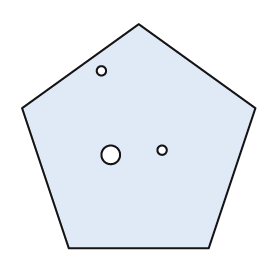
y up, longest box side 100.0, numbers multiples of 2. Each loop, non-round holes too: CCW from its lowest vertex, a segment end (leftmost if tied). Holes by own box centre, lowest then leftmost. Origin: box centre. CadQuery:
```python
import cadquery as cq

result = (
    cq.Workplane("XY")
    .moveTo(-30.0, -48.0)
    .lineTo(30.0, -48.0)
    .lineTo(50.0, 12.0)
    .lineTo(0.0, 48.0)
    .lineTo(-50.0, 12.0)
    .close()
    .moveTo(-12.0, -8.0)
    .circle(4.0)
    .moveTo(10.0, -6.0)
    .circle(2.0)
    .moveTo(-16.0, 28.0)
    .circle(2.0)
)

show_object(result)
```